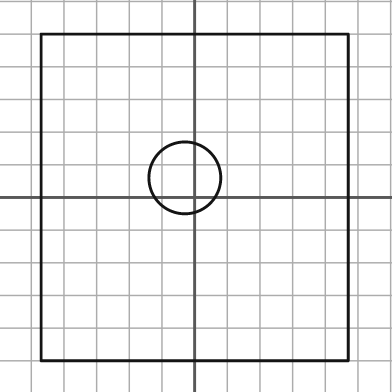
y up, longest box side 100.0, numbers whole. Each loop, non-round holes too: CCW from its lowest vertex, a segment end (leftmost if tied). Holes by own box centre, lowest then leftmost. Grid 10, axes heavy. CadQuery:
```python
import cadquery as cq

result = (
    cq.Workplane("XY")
    .moveTo(-47.0, -50.0)
    .lineTo(47.0, -50.0)
    .lineTo(47.0, 50.0)
    .lineTo(-47.0, 50.0)
    .close()
    .moveTo(-3.0, 6.0)
    .circle(11.0)
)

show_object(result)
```